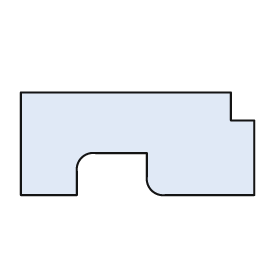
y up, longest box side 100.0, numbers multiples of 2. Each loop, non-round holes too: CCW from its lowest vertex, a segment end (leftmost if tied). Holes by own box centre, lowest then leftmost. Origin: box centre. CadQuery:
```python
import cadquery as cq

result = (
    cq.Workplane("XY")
    .moveTo(-50.0, -22.0)
    .lineTo(-26.0, -22.0)
    .lineTo(-26.0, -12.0)
    .threePointArc((-24.0, -6.0), (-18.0, -4.0))
    .lineTo(4.0, -4.0)
    .lineTo(4.0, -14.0)
    .threePointArc((6.0, -20.0), (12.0, -22.0))
    .lineTo(50.0, -22.0)
    .lineTo(50.0, 10.0)
    .lineTo(40.0, 10.0)
    .lineTo(40.0, 22.0)
    .lineTo(-50.0, 22.0)
    .close()
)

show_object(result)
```